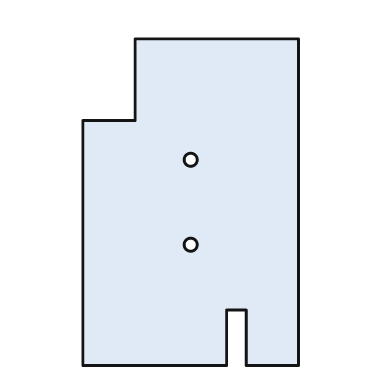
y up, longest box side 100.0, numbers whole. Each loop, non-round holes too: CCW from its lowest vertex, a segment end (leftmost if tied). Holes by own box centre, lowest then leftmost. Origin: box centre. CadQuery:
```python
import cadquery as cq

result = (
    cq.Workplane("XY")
    .moveTo(-33.0, -50.0)
    .lineTo(11.0, -50.0)
    .lineTo(11.0, -33.0)
    .lineTo(17.0, -33.0)
    .lineTo(17.0, -50.0)
    .lineTo(33.0, -50.0)
    .lineTo(33.0, 50.0)
    .lineTo(-17.0, 50.0)
    .lineTo(-17.0, 25.0)
    .lineTo(-33.0, 25.0)
    .close()
    .moveTo(0.0, -13.0)
    .circle(2.0)
    .moveTo(0.0, 13.0)
    .circle(2.0)
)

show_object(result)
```